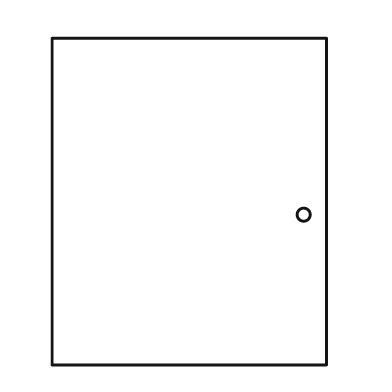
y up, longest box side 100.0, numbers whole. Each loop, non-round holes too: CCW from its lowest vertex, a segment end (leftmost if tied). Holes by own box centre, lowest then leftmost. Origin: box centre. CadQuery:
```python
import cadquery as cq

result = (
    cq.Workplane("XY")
    .moveTo(-42.0, -50.0)
    .lineTo(42.0, -50.0)
    .lineTo(42.0, 50.0)
    .lineTo(-42.0, 50.0)
    .close()
    .moveTo(35.0, -4.0)
    .circle(2.0)
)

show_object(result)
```